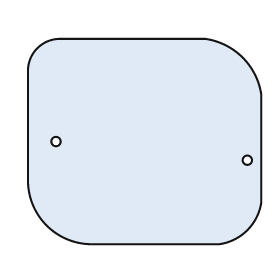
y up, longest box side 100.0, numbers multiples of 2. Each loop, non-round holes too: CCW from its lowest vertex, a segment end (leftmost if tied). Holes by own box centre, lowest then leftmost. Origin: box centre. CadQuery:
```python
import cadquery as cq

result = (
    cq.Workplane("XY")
    .moveTo(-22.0, -44.0)
    .lineTo(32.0, -44.0)
    .threePointArc((44.0, -38.0), (50.0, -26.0))
    .lineTo(50.0, 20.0)
    .threePointArc((42.0, 36.0), (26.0, 44.0))
    .lineTo(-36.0, 44.0)
    .threePointArc((-46.0, 40.0), (-50.0, 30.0))
    .lineTo(-50.0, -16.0)
    .threePointArc((-42.0, -36.0), (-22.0, -44.0))
    .close()
    .moveTo(44.0, -8.0)
    .circle(2.0)
    .moveTo(-38.0, 0.0)
    .circle(2.0)
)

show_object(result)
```